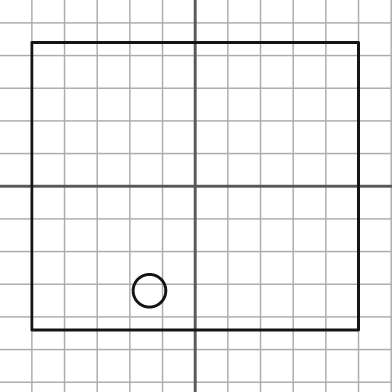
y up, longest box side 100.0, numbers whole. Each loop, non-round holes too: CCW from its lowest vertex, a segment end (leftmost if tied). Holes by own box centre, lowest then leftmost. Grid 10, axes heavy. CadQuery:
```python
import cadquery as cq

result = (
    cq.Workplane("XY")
    .moveTo(-50.0, -44.0)
    .lineTo(50.0, -44.0)
    .lineTo(50.0, 44.0)
    .lineTo(-50.0, 44.0)
    .close()
    .moveTo(-14.0, -32.0)
    .circle(5.0)
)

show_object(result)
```